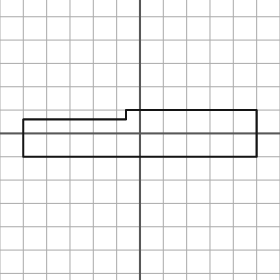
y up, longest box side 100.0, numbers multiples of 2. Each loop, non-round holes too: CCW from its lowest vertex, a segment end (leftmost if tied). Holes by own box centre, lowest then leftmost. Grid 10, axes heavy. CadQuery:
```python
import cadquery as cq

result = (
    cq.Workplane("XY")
    .moveTo(-50.0, -10.0)
    .lineTo(50.0, -10.0)
    .lineTo(50.0, 10.0)
    .lineTo(-6.0, 10.0)
    .lineTo(-6.0, 6.0)
    .lineTo(-50.0, 6.0)
    .close()
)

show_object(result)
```